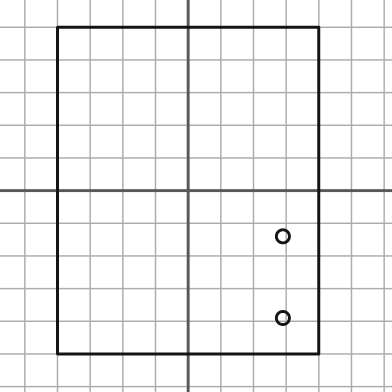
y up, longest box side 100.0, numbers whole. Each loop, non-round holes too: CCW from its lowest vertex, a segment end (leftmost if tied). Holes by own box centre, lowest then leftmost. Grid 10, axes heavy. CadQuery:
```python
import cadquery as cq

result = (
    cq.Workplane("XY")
    .moveTo(-40.0, -50.0)
    .lineTo(40.0, -50.0)
    .lineTo(40.0, 50.0)
    .lineTo(-40.0, 50.0)
    .close()
    .moveTo(29.0, -39.0)
    .circle(2.0)
    .moveTo(29.0, -14.0)
    .circle(2.0)
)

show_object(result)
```